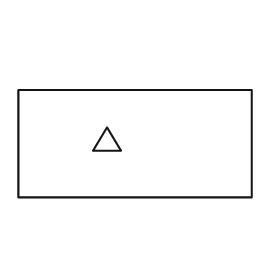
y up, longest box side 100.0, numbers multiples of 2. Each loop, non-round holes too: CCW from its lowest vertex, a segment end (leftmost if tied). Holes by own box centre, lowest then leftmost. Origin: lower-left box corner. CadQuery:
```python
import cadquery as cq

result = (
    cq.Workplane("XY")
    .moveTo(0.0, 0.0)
    .lineTo(100.0, 0.0)
    .lineTo(100.0, 46.0)
    .lineTo(0.0, 46.0)
    .close()
    .moveTo(32.0, 20.0)
    .lineTo(44.0, 20.0)
    .lineTo(38.0, 30.0)
    .close()
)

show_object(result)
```